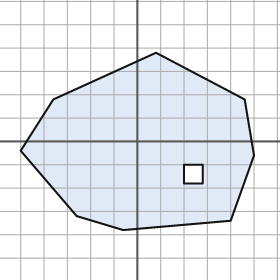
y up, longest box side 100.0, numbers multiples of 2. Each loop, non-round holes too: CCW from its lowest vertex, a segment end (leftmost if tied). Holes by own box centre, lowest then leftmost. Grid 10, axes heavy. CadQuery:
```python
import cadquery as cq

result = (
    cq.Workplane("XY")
    .moveTo(-6.0, -38.0)
    .lineTo(40.0, -34.0)
    .lineTo(50.0, -6.0)
    .lineTo(46.0, 18.0)
    .lineTo(8.0, 38.0)
    .lineTo(-36.0, 18.0)
    .lineTo(-50.0, -4.0)
    .lineTo(-26.0, -32.0)
    .close()
    .moveTo(20.0, -18.0)
    .lineTo(28.0, -18.0)
    .lineTo(28.0, -10.0)
    .lineTo(20.0, -10.0)
    .close()
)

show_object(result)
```